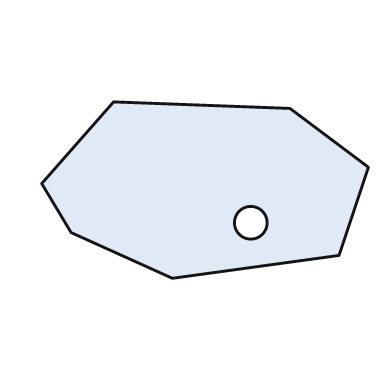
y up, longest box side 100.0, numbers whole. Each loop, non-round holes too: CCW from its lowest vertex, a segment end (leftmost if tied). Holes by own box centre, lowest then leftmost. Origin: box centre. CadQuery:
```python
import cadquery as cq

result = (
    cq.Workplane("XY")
    .moveTo(-10.0, -27.0)
    .lineTo(41.0, -20.0)
    .lineTo(50.0, 7.0)
    .lineTo(26.0, 25.0)
    .lineTo(-28.0, 27.0)
    .lineTo(-50.0, 2.0)
    .lineTo(-41.0, -13.0)
    .close()
    .moveTo(14.0, -10.0)
    .circle(5.0)
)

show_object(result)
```